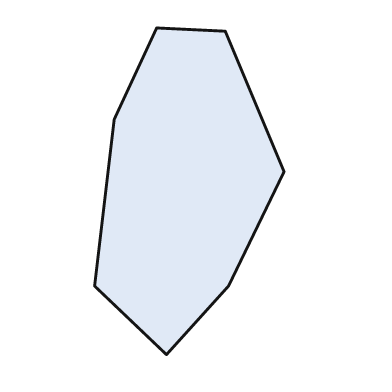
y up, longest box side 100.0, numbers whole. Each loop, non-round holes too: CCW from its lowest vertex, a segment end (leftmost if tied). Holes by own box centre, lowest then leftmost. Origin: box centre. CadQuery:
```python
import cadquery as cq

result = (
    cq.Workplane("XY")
    .moveTo(-7.0, -50.0)
    .lineTo(12.0, -29.0)
    .lineTo(29.0, 6.0)
    .lineTo(11.0, 49.0)
    .lineTo(-10.0, 50.0)
    .lineTo(-23.0, 22.0)
    .lineTo(-29.0, -29.0)
    .close()
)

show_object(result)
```